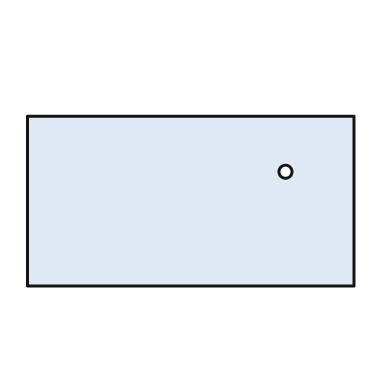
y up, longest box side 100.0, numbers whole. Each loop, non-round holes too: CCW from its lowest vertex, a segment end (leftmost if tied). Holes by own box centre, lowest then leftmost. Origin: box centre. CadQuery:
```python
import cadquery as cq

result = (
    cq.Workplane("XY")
    .moveTo(-50.0, -26.0)
    .lineTo(50.0, -26.0)
    .lineTo(50.0, 26.0)
    .lineTo(-50.0, 26.0)
    .close()
    .moveTo(29.0, 9.0)
    .circle(2.0)
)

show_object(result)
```